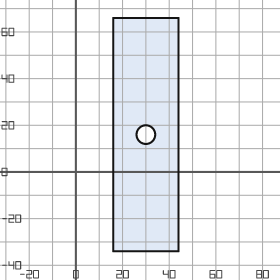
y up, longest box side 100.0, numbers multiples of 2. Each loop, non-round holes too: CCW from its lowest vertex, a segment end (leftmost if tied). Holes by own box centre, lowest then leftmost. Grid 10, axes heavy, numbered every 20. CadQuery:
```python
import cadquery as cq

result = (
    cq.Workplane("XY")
    .moveTo(16.0, -34.0)
    .lineTo(44.0, -34.0)
    .lineTo(44.0, 66.0)
    .lineTo(16.0, 66.0)
    .close()
    .moveTo(30.0, 16.0)
    .circle(4.0)
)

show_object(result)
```